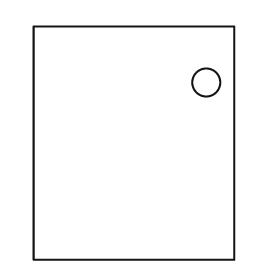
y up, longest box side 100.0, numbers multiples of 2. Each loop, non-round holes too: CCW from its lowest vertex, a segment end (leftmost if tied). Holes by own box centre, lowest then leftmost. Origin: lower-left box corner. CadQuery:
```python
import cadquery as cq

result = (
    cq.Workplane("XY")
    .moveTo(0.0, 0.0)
    .lineTo(86.0, 0.0)
    .lineTo(86.0, 100.0)
    .lineTo(0.0, 100.0)
    .close()
    .moveTo(74.0, 76.0)
    .circle(6.0)
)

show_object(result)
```